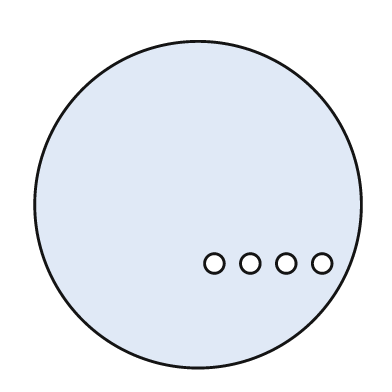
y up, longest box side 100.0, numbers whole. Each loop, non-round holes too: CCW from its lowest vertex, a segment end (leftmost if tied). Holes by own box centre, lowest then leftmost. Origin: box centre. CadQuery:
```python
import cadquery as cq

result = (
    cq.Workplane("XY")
    .moveTo(0.0, 0.0)
    .circle(50.0)
    .moveTo(5.0, -18.0)
    .circle(3.0)
    .moveTo(16.0, -18.0)
    .circle(3.0)
    .moveTo(27.0, -18.0)
    .circle(3.0)
    .moveTo(38.0, -18.0)
    .circle(3.0)
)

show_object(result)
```